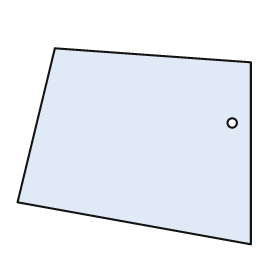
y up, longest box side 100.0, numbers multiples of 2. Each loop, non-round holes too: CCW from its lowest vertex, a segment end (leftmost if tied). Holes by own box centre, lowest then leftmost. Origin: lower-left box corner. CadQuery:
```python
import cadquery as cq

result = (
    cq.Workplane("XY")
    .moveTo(100.0, 0.0)
    .lineTo(100.0, 78.0)
    .lineTo(16.0, 84.0)
    .lineTo(0.0, 18.0)
    .close()
    .moveTo(92.0, 52.0)
    .circle(2.0)
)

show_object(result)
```